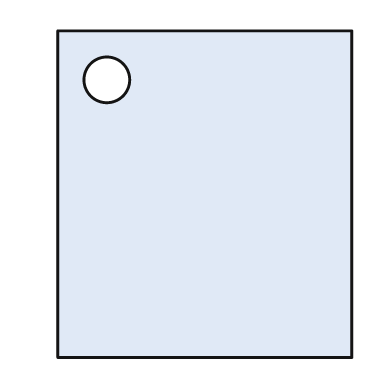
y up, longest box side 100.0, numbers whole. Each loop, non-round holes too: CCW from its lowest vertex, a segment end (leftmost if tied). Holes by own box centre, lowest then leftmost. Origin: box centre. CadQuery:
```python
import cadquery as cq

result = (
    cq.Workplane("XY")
    .moveTo(-45.0, -50.0)
    .lineTo(45.0, -50.0)
    .lineTo(45.0, 50.0)
    .lineTo(-45.0, 50.0)
    .close()
    .moveTo(-30.0, 35.0)
    .circle(7.0)
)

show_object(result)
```